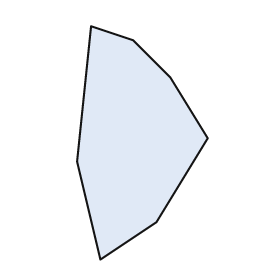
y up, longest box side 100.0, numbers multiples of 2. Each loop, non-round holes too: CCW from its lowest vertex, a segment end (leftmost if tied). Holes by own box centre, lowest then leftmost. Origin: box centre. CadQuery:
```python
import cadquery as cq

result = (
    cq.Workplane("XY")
    .moveTo(-18.0, -50.0)
    .lineTo(6.0, -34.0)
    .lineTo(28.0, 2.0)
    .lineTo(12.0, 28.0)
    .lineTo(-4.0, 44.0)
    .lineTo(-22.0, 50.0)
    .lineTo(-28.0, -8.0)
    .close()
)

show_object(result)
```